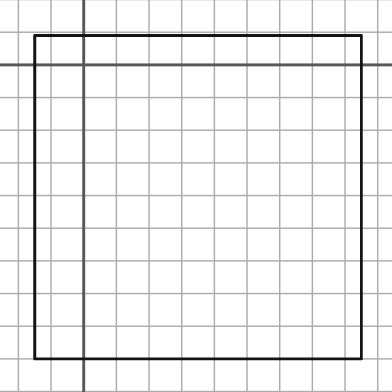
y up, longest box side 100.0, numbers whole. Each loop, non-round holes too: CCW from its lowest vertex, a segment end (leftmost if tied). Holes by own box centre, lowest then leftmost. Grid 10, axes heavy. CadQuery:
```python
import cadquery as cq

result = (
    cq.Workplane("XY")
    .moveTo(-15.0, -90.0)
    .lineTo(85.0, -90.0)
    .lineTo(85.0, 9.0)
    .lineTo(-15.0, 9.0)
    .close()
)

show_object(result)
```